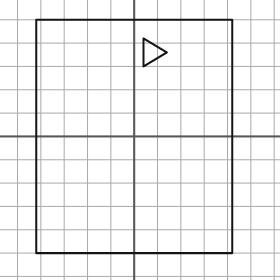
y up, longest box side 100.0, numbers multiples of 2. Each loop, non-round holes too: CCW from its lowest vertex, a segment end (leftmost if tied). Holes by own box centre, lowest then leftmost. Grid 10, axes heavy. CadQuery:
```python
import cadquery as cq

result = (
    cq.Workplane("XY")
    .moveTo(-42.0, -50.0)
    .lineTo(42.0, -50.0)
    .lineTo(42.0, 50.0)
    .lineTo(-42.0, 50.0)
    .close()
    .moveTo(4.0, 30.0)
    .lineTo(14.0, 36.0)
    .lineTo(4.0, 42.0)
    .close()
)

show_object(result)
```